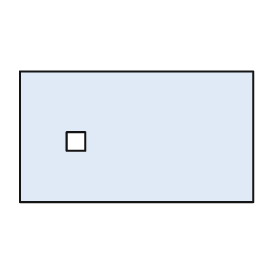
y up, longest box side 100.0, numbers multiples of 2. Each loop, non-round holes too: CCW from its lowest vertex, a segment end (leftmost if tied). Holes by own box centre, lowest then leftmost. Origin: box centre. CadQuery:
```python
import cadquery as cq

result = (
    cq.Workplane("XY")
    .moveTo(-50.0, -28.0)
    .lineTo(50.0, -28.0)
    .lineTo(50.0, 28.0)
    .lineTo(-50.0, 28.0)
    .close()
    .moveTo(-30.0, -6.0)
    .lineTo(-22.0, -6.0)
    .lineTo(-22.0, 2.0)
    .lineTo(-30.0, 2.0)
    .close()
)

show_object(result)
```